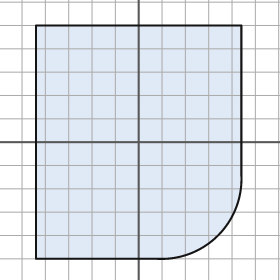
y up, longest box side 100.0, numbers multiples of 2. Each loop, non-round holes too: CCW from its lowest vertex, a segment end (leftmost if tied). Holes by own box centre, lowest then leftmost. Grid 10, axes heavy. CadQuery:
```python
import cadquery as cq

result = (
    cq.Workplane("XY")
    .moveTo(-44.0, -50.0)
    .lineTo(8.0, -50.0)
    .threePointArc((34.0, -40.0), (44.0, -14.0))
    .lineTo(44.0, 50.0)
    .lineTo(-44.0, 50.0)
    .close()
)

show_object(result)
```